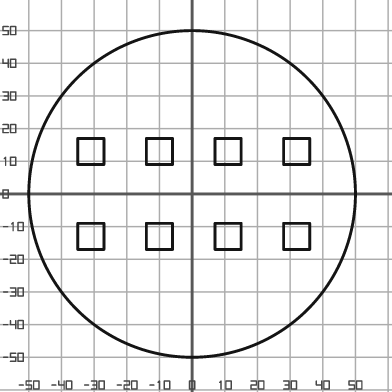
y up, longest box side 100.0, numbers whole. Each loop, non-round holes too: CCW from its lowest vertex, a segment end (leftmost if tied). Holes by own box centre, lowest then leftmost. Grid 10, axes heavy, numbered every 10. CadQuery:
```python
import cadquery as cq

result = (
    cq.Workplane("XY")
    .moveTo(0.0, 0.0)
    .circle(50.0)
    .moveTo(-35.0, -17.0)
    .lineTo(-27.0, -17.0)
    .lineTo(-27.0, -9.0)
    .lineTo(-35.0, -9.0)
    .close()
    .moveTo(-14.0, -17.0)
    .lineTo(-6.0, -17.0)
    .lineTo(-6.0, -9.0)
    .lineTo(-14.0, -9.0)
    .close()
    .moveTo(7.0, -17.0)
    .lineTo(15.0, -17.0)
    .lineTo(15.0, -9.0)
    .lineTo(7.0, -9.0)
    .close()
    .moveTo(28.0, -17.0)
    .lineTo(36.0, -17.0)
    .lineTo(36.0, -9.0)
    .lineTo(28.0, -9.0)
    .close()
    .moveTo(-35.0, 9.0)
    .lineTo(-27.0, 9.0)
    .lineTo(-27.0, 17.0)
    .lineTo(-35.0, 17.0)
    .close()
    .moveTo(-14.0, 9.0)
    .lineTo(-6.0, 9.0)
    .lineTo(-6.0, 17.0)
    .lineTo(-14.0, 17.0)
    .close()
    .moveTo(7.0, 9.0)
    .lineTo(15.0, 9.0)
    .lineTo(15.0, 17.0)
    .lineTo(7.0, 17.0)
    .close()
    .moveTo(28.0, 9.0)
    .lineTo(36.0, 9.0)
    .lineTo(36.0, 17.0)
    .lineTo(28.0, 17.0)
    .close()
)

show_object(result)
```